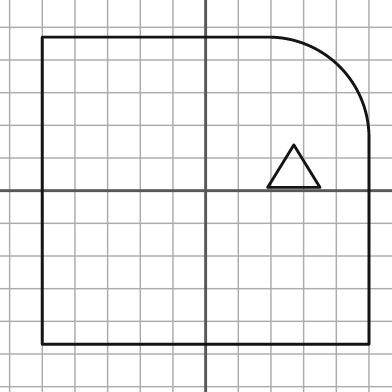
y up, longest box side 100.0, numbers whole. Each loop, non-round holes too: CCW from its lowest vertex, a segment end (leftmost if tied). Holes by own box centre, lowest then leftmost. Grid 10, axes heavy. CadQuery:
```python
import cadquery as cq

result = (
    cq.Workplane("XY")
    .moveTo(-50.0, -47.0)
    .lineTo(50.0, -47.0)
    .lineTo(50.0, 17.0)
    .threePointArc((41.0, 38.0), (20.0, 47.0))
    .lineTo(-50.0, 47.0)
    .close()
    .moveTo(19.0, 1.0)
    .lineTo(35.0, 1.0)
    .lineTo(27.0, 14.0)
    .close()
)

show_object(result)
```